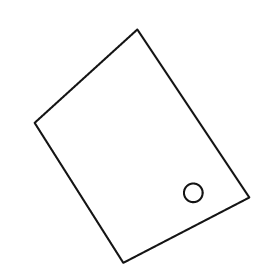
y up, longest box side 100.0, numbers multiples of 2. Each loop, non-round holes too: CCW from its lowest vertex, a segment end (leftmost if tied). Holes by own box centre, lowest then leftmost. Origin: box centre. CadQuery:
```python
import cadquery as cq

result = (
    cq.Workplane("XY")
    .moveTo(-8.0, -50.0)
    .lineTo(46.0, -22.0)
    .lineTo(-2.0, 50.0)
    .lineTo(-46.0, 10.0)
    .close()
    .moveTo(22.0, -20.0)
    .circle(4.0)
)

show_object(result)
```